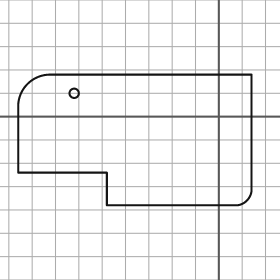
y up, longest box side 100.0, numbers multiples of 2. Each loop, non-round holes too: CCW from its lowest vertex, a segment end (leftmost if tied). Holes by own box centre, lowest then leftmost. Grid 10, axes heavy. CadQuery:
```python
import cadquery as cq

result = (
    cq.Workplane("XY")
    .moveTo(-48.0, -38.0)
    .lineTo(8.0, -38.0)
    .threePointArc((12.0, -36.0), (14.0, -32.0))
    .lineTo(14.0, 18.0)
    .lineTo(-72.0, 18.0)
    .threePointArc((-82.0, 14.0), (-86.0, 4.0))
    .lineTo(-86.0, -24.0)
    .lineTo(-48.0, -24.0)
    .close()
    .moveTo(-62.0, 10.0)
    .circle(2.0)
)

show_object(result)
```